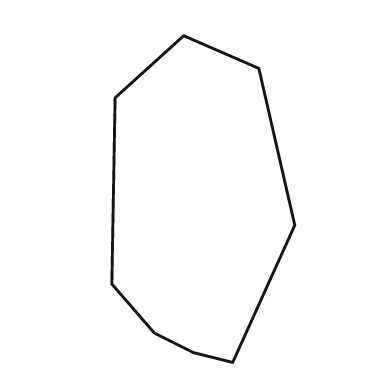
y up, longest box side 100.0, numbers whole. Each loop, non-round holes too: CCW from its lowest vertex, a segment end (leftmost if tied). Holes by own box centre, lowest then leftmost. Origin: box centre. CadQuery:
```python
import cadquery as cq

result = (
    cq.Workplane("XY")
    .moveTo(9.0, -50.0)
    .lineTo(28.0, -8.0)
    .lineTo(17.0, 40.0)
    .lineTo(-6.0, 50.0)
    .lineTo(-27.0, 31.0)
    .lineTo(-28.0, -26.0)
    .lineTo(-15.0, -41.0)
    .lineTo(-3.0, -47.0)
    .close()
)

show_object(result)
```